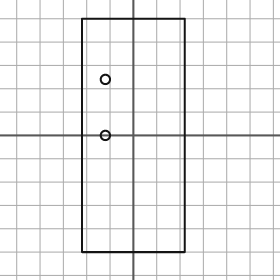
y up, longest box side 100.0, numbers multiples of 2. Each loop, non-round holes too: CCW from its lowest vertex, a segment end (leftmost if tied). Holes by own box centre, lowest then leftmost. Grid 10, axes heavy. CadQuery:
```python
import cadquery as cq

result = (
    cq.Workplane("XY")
    .moveTo(-22.0, -50.0)
    .lineTo(22.0, -50.0)
    .lineTo(22.0, 50.0)
    .lineTo(-22.0, 50.0)
    .close()
    .moveTo(-12.0, 0.0)
    .circle(2.0)
    .moveTo(-12.0, 24.0)
    .circle(2.0)
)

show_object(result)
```